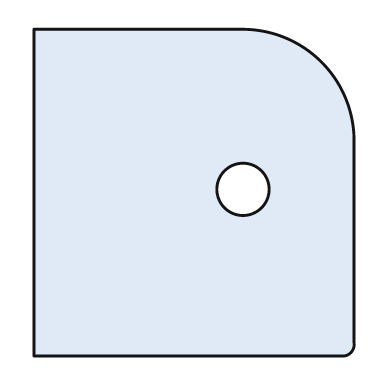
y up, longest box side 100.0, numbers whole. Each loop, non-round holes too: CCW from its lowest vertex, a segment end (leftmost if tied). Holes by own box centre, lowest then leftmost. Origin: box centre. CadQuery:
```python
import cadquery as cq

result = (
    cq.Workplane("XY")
    .moveTo(-49.0, -50.0)
    .lineTo(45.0, -50.0)
    .threePointArc((48.0, -49.0), (49.0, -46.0))
    .lineTo(49.0, 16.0)
    .threePointArc((39.0, 40.0), (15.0, 50.0))
    .lineTo(-49.0, 50.0)
    .close()
    .moveTo(15.0, 1.0)
    .circle(8.0)
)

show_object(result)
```